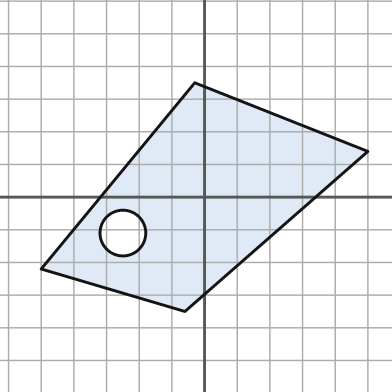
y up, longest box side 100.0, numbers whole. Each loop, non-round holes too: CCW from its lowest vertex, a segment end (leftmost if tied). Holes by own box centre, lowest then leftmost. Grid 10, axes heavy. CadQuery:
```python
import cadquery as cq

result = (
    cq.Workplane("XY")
    .moveTo(-6.0, -35.0)
    .lineTo(50.0, 14.0)
    .lineTo(-3.0, 35.0)
    .lineTo(-50.0, -22.0)
    .close()
    .moveTo(-25.0, -11.0)
    .circle(7.0)
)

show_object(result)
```